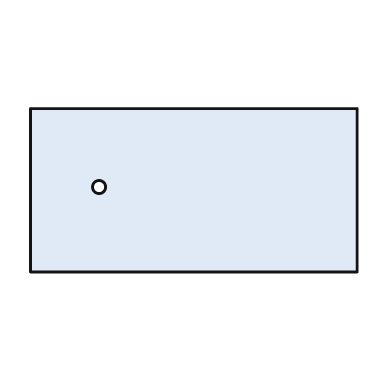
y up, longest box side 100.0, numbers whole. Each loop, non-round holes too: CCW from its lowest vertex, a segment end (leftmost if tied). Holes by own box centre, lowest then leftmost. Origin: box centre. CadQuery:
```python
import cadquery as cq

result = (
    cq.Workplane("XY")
    .moveTo(-50.0, -25.0)
    .lineTo(50.0, -25.0)
    .lineTo(50.0, 25.0)
    .lineTo(-50.0, 25.0)
    .close()
    .moveTo(-29.0, 1.0)
    .circle(2.0)
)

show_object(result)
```